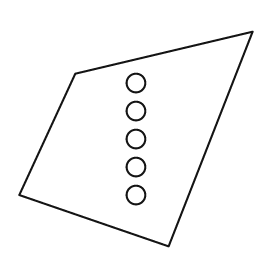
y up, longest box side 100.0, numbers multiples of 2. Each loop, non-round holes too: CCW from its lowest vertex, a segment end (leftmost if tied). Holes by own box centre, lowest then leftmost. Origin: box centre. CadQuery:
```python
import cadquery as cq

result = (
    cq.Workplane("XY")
    .moveTo(14.0, -46.0)
    .lineTo(50.0, 46.0)
    .lineTo(-26.0, 28.0)
    .lineTo(-50.0, -24.0)
    .close()
    .moveTo(0.0, -24.0)
    .circle(4.0)
    .moveTo(0.0, -12.0)
    .circle(4.0)
    .moveTo(0.0, 0.0)
    .circle(4.0)
    .moveTo(0.0, 12.0)
    .circle(4.0)
    .moveTo(0.0, 24.0)
    .circle(4.0)
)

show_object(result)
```